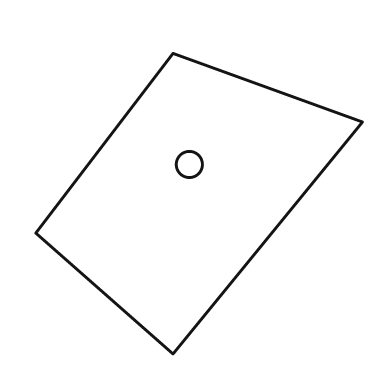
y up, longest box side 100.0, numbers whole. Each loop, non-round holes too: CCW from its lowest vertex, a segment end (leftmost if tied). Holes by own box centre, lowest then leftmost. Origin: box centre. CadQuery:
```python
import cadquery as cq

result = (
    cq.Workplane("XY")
    .moveTo(-8.0, -46.0)
    .lineTo(50.0, 25.0)
    .lineTo(-8.0, 46.0)
    .lineTo(-50.0, -9.0)
    .close()
    .moveTo(-3.0, 12.0)
    .circle(4.0)
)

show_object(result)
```